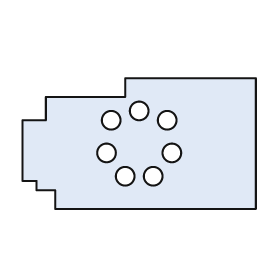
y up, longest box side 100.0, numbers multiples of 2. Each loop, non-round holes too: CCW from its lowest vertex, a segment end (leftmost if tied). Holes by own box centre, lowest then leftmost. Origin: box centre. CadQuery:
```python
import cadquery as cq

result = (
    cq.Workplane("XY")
    .moveTo(-36.0, -28.0)
    .lineTo(50.0, -28.0)
    .lineTo(50.0, 28.0)
    .lineTo(-6.0, 28.0)
    .lineTo(-6.0, 20.0)
    .lineTo(-40.0, 20.0)
    .lineTo(-40.0, 10.0)
    .lineTo(-50.0, 10.0)
    .lineTo(-50.0, -16.0)
    .lineTo(-44.0, -16.0)
    .lineTo(-44.0, -20.0)
    .lineTo(-36.0, -20.0)
    .close()
    .moveTo(-6.0, -14.0)
    .circle(4.0)
    .moveTo(6.0, -14.0)
    .circle(4.0)
    .moveTo(-14.0, -4.0)
    .circle(4.0)
    .moveTo(14.0, -4.0)
    .circle(4.0)
    .moveTo(-12.0, 10.0)
    .circle(4.0)
    .moveTo(12.0, 10.0)
    .circle(4.0)
    .moveTo(0.0, 14.0)
    .circle(4.0)
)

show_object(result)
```